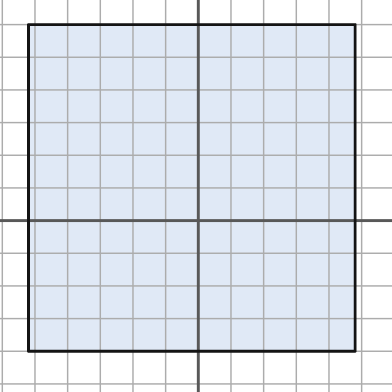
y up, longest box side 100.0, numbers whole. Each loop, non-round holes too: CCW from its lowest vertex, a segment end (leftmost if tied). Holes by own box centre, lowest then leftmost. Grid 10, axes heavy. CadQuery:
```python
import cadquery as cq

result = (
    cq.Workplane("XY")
    .moveTo(-52.0, -40.0)
    .lineTo(48.0, -40.0)
    .lineTo(48.0, 60.0)
    .lineTo(-52.0, 60.0)
    .close()
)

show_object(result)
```